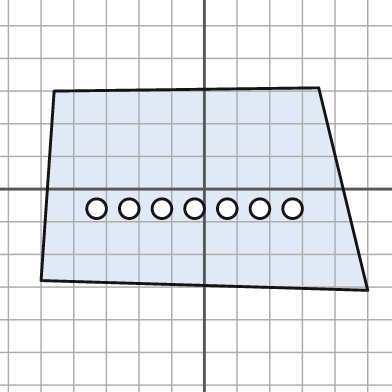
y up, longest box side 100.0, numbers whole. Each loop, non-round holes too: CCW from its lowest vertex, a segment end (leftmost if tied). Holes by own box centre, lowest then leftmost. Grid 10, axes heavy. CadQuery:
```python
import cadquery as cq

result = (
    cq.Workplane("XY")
    .moveTo(50.0, -31.0)
    .lineTo(35.0, 31.0)
    .lineTo(-46.0, 30.0)
    .lineTo(-50.0, -28.0)
    .close()
    .moveTo(-33.0, -6.0)
    .circle(3.0)
    .moveTo(-23.0, -6.0)
    .circle(3.0)
    .moveTo(-13.0, -6.0)
    .circle(3.0)
    .moveTo(-3.0, -6.0)
    .circle(3.0)
    .moveTo(7.0, -6.0)
    .circle(3.0)
    .moveTo(17.0, -6.0)
    .circle(3.0)
    .moveTo(27.0, -6.0)
    .circle(3.0)
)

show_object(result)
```